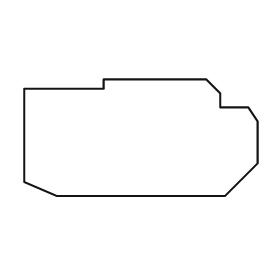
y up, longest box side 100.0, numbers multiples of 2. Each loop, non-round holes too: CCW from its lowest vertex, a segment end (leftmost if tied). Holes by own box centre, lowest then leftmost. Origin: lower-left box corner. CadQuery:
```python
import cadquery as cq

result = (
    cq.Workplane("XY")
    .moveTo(14.0, 0.0)
    .lineTo(86.0, 0.0)
    .lineTo(100.0, 14.0)
    .lineTo(100.0, 32.0)
    .lineTo(96.0, 38.0)
    .lineTo(84.0, 38.0)
    .lineTo(84.0, 44.0)
    .lineTo(78.0, 50.0)
    .lineTo(34.0, 50.0)
    .lineTo(34.0, 46.0)
    .lineTo(0.0, 46.0)
    .lineTo(0.0, 6.0)
    .close()
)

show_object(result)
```